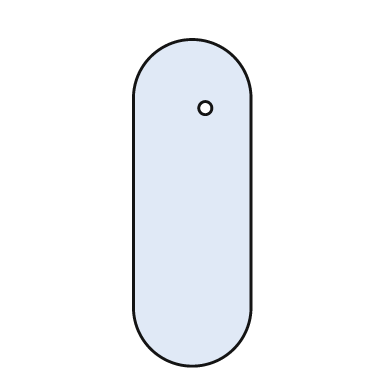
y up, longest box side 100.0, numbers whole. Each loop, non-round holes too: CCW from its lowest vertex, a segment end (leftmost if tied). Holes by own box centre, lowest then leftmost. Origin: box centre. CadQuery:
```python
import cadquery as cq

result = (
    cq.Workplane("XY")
    .moveTo(-18.0, -32.0)
    .threePointArc((0.0, -50.0), (18.0, -32.0))
    .lineTo(18.0, 32.0)
    .threePointArc((0.0, 50.0), (-18.0, 32.0))
    .close()
    .moveTo(4.0, 29.0)
    .circle(2.0)
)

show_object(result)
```